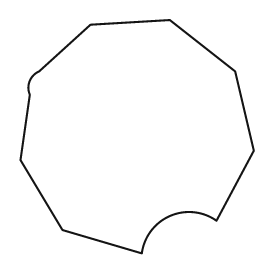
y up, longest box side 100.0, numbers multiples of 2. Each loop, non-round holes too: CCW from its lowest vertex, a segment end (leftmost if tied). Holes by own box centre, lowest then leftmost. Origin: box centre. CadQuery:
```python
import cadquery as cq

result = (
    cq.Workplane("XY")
    .moveTo(2.0, -50.0)
    .threePointArc((14.0, -34.0), (34.0, -36.0))
    .lineTo(50.0, -6.0)
    .lineTo(42.0, 28.0)
    .lineTo(14.0, 50.0)
    .lineTo(-20.0, 48.0)
    .lineTo(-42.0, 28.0)
    .threePointArc((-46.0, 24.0), (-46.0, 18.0))
    .lineTo(-50.0, -10.0)
    .lineTo(-32.0, -40.0)
    .close()
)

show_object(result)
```